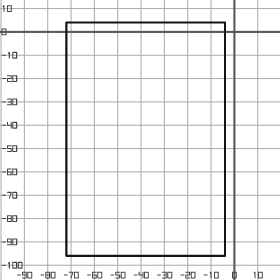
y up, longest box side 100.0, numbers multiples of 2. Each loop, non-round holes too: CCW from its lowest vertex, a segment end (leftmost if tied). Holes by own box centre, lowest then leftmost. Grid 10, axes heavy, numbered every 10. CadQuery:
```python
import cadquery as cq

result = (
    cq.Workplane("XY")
    .moveTo(-72.0, -96.0)
    .lineTo(-4.0, -96.0)
    .lineTo(-4.0, 4.0)
    .lineTo(-72.0, 4.0)
    .close()
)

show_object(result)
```